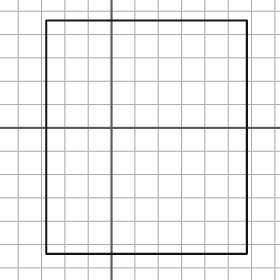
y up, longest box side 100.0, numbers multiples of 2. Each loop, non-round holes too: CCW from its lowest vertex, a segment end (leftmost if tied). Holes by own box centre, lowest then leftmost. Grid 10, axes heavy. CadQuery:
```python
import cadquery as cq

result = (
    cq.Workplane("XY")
    .moveTo(-28.0, -54.0)
    .lineTo(58.0, -54.0)
    .lineTo(58.0, 46.0)
    .lineTo(-28.0, 46.0)
    .close()
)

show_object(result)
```